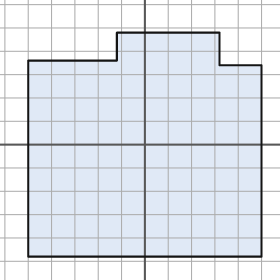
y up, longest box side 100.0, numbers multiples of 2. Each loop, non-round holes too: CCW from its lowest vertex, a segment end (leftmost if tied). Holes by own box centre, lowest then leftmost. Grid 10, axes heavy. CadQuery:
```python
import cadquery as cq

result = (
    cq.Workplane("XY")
    .moveTo(-50.0, -48.0)
    .lineTo(50.0, -48.0)
    .lineTo(50.0, 34.0)
    .lineTo(32.0, 34.0)
    .lineTo(32.0, 48.0)
    .lineTo(-12.0, 48.0)
    .lineTo(-12.0, 36.0)
    .lineTo(-50.0, 36.0)
    .close()
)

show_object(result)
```